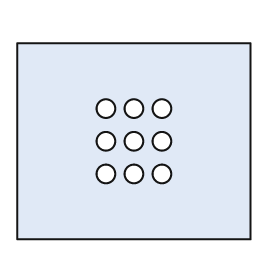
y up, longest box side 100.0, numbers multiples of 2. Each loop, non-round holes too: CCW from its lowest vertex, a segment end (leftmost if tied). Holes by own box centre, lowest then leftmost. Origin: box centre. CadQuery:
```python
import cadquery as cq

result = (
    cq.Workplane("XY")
    .moveTo(-50.0, -42.0)
    .lineTo(50.0, -42.0)
    .lineTo(50.0, 42.0)
    .lineTo(-50.0, 42.0)
    .close()
    .moveTo(-12.0, -14.0)
    .circle(4.0)
    .moveTo(0.0, -14.0)
    .circle(4.0)
    .moveTo(12.0, -14.0)
    .circle(4.0)
    .moveTo(-12.0, 0.0)
    .circle(4.0)
    .moveTo(0.0, 0.0)
    .circle(4.0)
    .moveTo(12.0, 0.0)
    .circle(4.0)
    .moveTo(-12.0, 14.0)
    .circle(4.0)
    .moveTo(0.0, 14.0)
    .circle(4.0)
    .moveTo(12.0, 14.0)
    .circle(4.0)
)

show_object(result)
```